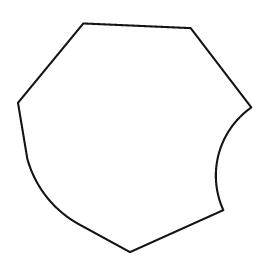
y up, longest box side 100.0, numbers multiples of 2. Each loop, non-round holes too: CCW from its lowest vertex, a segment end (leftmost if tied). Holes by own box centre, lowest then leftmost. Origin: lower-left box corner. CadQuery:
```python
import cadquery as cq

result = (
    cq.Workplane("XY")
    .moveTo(48.0, 0.0)
    .lineTo(88.0, 18.0)
    .threePointArc((86.0, 42.0), (100.0, 62.0))
    .lineTo(74.0, 96.0)
    .lineTo(28.0, 98.0)
    .lineTo(0.0, 64.0)
    .lineTo(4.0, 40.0)
    .threePointArc((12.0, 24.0), (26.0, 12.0))
    .close()
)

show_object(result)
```